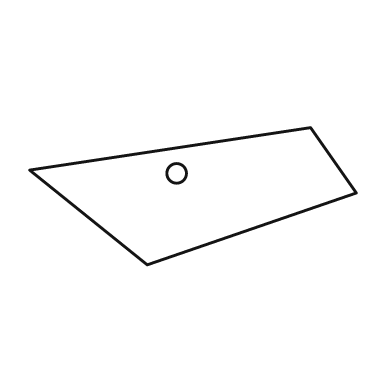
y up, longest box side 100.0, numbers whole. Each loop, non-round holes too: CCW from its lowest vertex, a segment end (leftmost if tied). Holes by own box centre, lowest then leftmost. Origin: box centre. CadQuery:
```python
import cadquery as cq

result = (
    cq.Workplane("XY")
    .moveTo(-14.0, -21.0)
    .lineTo(50.0, 1.0)
    .lineTo(36.0, 21.0)
    .lineTo(-50.0, 8.0)
    .close()
    .moveTo(-5.0, 7.0)
    .circle(3.0)
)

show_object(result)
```